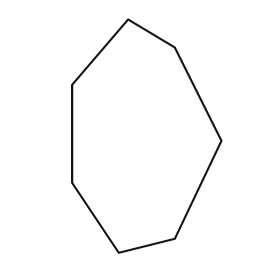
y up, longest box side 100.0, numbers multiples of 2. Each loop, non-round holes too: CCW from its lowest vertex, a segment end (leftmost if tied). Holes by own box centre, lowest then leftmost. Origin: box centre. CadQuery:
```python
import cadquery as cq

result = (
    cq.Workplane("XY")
    .moveTo(-12.0, -50.0)
    .lineTo(12.0, -44.0)
    .lineTo(32.0, -2.0)
    .lineTo(12.0, 38.0)
    .lineTo(-8.0, 50.0)
    .lineTo(-32.0, 22.0)
    .lineTo(-32.0, -20.0)
    .close()
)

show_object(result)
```